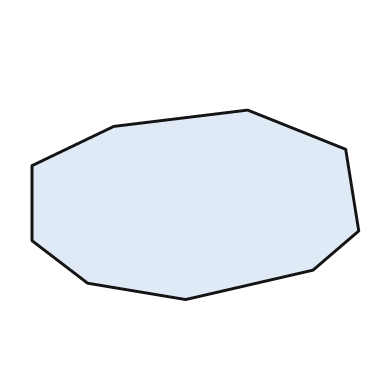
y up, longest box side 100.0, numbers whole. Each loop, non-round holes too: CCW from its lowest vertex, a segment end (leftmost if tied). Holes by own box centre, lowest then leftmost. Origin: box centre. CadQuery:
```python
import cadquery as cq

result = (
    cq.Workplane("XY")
    .moveTo(-3.0, -29.0)
    .lineTo(36.0, -20.0)
    .lineTo(50.0, -8.0)
    .lineTo(46.0, 17.0)
    .lineTo(16.0, 29.0)
    .lineTo(-25.0, 24.0)
    .lineTo(-50.0, 12.0)
    .lineTo(-50.0, -11.0)
    .lineTo(-33.0, -24.0)
    .close()
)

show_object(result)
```